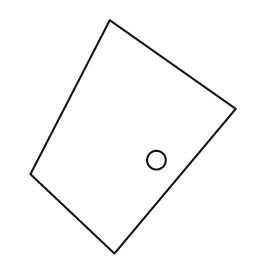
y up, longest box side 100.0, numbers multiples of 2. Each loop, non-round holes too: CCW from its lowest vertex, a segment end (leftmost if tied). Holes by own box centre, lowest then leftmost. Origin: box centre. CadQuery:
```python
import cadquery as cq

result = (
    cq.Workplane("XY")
    .moveTo(-8.0, -50.0)
    .lineTo(44.0, 12.0)
    .lineTo(-10.0, 50.0)
    .lineTo(-44.0, -16.0)
    .close()
    .moveTo(10.0, -10.0)
    .circle(4.0)
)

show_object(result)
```